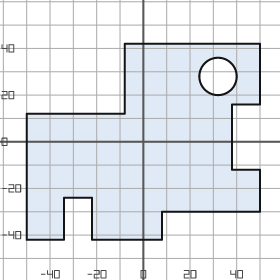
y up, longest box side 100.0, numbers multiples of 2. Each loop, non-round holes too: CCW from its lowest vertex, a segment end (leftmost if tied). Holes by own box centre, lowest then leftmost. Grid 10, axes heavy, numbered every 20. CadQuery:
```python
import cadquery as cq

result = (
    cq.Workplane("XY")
    .moveTo(-50.0, -42.0)
    .lineTo(-34.0, -42.0)
    .lineTo(-34.0, -24.0)
    .lineTo(-22.0, -24.0)
    .lineTo(-22.0, -42.0)
    .lineTo(8.0, -42.0)
    .lineTo(8.0, -30.0)
    .lineTo(50.0, -30.0)
    .lineTo(50.0, -12.0)
    .lineTo(38.0, -12.0)
    .lineTo(38.0, 16.0)
    .lineTo(50.0, 16.0)
    .lineTo(50.0, 42.0)
    .lineTo(-8.0, 42.0)
    .lineTo(-8.0, 12.0)
    .lineTo(-50.0, 12.0)
    .close()
    .moveTo(32.0, 28.0)
    .circle(8.0)
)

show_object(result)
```